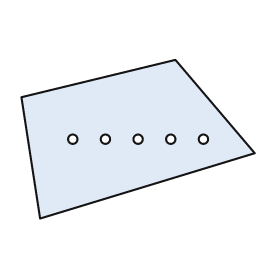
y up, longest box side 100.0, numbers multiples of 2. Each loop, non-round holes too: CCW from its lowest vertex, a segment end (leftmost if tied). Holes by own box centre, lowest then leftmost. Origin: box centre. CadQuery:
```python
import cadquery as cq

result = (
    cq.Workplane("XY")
    .moveTo(-42.0, -34.0)
    .lineTo(50.0, -6.0)
    .lineTo(16.0, 34.0)
    .lineTo(-50.0, 18.0)
    .close()
    .moveTo(-28.0, 0.0)
    .circle(2.0)
    .moveTo(-14.0, 0.0)
    .circle(2.0)
    .moveTo(0.0, 0.0)
    .circle(2.0)
    .moveTo(14.0, 0.0)
    .circle(2.0)
    .moveTo(28.0, 0.0)
    .circle(2.0)
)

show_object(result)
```